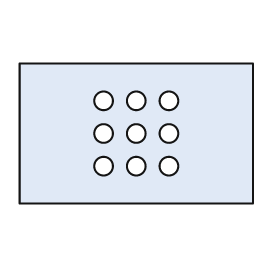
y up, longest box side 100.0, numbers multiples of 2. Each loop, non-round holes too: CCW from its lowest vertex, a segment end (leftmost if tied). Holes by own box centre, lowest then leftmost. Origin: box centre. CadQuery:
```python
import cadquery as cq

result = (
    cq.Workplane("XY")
    .moveTo(-50.0, -30.0)
    .lineTo(50.0, -30.0)
    .lineTo(50.0, 30.0)
    .lineTo(-50.0, 30.0)
    .close()
    .moveTo(-14.0, -14.0)
    .circle(4.0)
    .moveTo(0.0, -14.0)
    .circle(4.0)
    .moveTo(14.0, -14.0)
    .circle(4.0)
    .moveTo(-14.0, 0.0)
    .circle(4.0)
    .moveTo(0.0, 0.0)
    .circle(4.0)
    .moveTo(14.0, 0.0)
    .circle(4.0)
    .moveTo(-14.0, 14.0)
    .circle(4.0)
    .moveTo(0.0, 14.0)
    .circle(4.0)
    .moveTo(14.0, 14.0)
    .circle(4.0)
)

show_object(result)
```